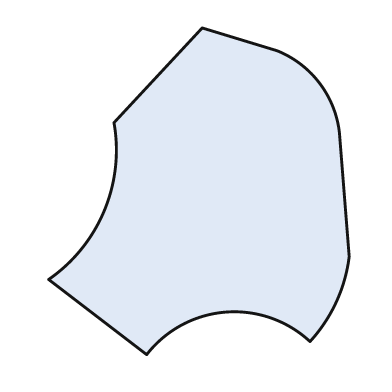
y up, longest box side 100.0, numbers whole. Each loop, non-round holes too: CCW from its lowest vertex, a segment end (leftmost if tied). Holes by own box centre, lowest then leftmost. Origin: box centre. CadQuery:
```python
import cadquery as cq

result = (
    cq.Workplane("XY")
    .moveTo(-16.0, -50.0)
    .threePointArc((8.0, -37.0), (34.0, -46.0))
    .threePointArc((42.0, -34.0), (46.0, -20.0))
    .lineTo(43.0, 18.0)
    .threePointArc((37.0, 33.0), (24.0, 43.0))
    .lineTo(1.0, 50.0)
    .lineTo(-26.0, 21.0)
    .threePointArc((-29.0, -6.0), (-46.0, -27.0))
    .close()
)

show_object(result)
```